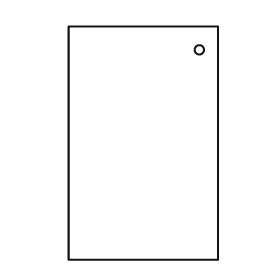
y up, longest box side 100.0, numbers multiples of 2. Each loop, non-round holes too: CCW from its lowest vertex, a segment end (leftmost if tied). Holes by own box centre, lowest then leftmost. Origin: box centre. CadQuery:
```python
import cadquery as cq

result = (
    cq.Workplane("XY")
    .moveTo(-32.0, -50.0)
    .lineTo(32.0, -50.0)
    .lineTo(32.0, 50.0)
    .lineTo(-32.0, 50.0)
    .close()
    .moveTo(24.0, 40.0)
    .circle(2.0)
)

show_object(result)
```